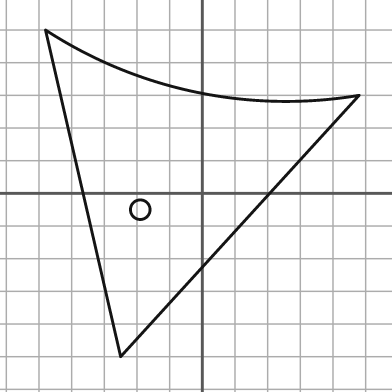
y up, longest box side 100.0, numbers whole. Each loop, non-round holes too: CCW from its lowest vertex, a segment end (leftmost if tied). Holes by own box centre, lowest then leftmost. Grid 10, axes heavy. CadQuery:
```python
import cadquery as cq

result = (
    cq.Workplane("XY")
    .moveTo(-25.0, -50.0)
    .lineTo(48.0, 30.0)
    .threePointArc((-2.0, 31.0), (-48.0, 50.0))
    .close()
    .moveTo(-19.0, -5.0)
    .circle(3.0)
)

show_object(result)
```